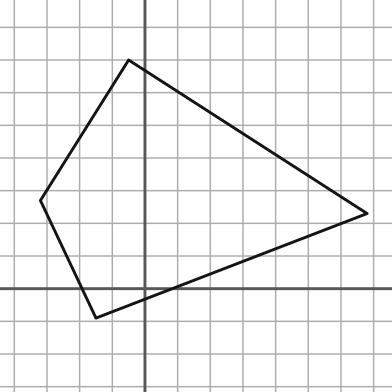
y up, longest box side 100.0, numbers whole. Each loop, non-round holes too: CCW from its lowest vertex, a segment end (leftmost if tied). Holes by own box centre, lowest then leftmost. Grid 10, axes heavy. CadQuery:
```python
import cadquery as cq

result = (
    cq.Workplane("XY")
    .moveTo(-15.0, -9.0)
    .lineTo(68.0, 23.0)
    .lineTo(-5.0, 70.0)
    .lineTo(-32.0, 27.0)
    .close()
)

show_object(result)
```